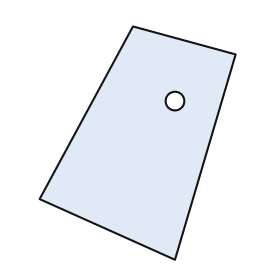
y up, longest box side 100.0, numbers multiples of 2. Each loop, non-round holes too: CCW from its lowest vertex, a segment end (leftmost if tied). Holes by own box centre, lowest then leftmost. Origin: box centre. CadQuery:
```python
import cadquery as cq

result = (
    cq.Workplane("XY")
    .moveTo(16.0, -50.0)
    .lineTo(42.0, 38.0)
    .lineTo(-2.0, 50.0)
    .lineTo(-42.0, -24.0)
    .close()
    .moveTo(16.0, 18.0)
    .circle(4.0)
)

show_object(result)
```